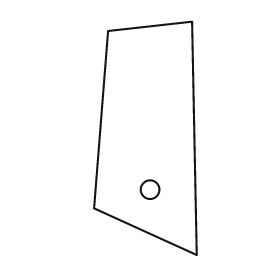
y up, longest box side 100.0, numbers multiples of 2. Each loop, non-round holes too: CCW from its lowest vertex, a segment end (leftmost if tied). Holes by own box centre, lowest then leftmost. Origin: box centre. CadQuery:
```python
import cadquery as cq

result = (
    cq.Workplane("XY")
    .moveTo(22.0, -50.0)
    .lineTo(20.0, 50.0)
    .lineTo(-16.0, 46.0)
    .lineTo(-22.0, -30.0)
    .close()
    .moveTo(2.0, -22.0)
    .circle(4.0)
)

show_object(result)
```